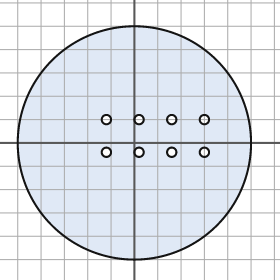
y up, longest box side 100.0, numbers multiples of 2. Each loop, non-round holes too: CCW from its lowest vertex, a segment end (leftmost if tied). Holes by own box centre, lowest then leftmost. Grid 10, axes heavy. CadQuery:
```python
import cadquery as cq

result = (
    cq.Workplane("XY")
    .moveTo(0.0, 0.0)
    .circle(50.0)
    .moveTo(-12.0, -4.0)
    .circle(2.0)
    .moveTo(2.0, -4.0)
    .circle(2.0)
    .moveTo(16.0, -4.0)
    .circle(2.0)
    .moveTo(30.0, -4.0)
    .circle(2.0)
    .moveTo(-12.0, 10.0)
    .circle(2.0)
    .moveTo(2.0, 10.0)
    .circle(2.0)
    .moveTo(16.0, 10.0)
    .circle(2.0)
    .moveTo(30.0, 10.0)
    .circle(2.0)
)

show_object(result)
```